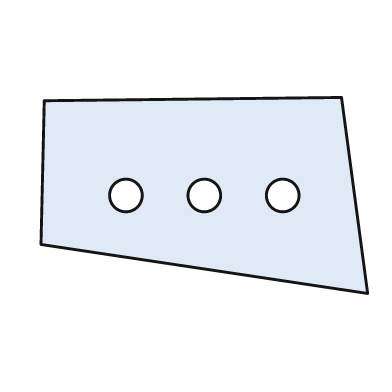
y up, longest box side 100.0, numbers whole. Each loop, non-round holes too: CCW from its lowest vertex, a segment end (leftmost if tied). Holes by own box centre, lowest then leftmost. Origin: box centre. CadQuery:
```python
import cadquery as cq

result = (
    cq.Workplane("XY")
    .moveTo(50.0, -30.0)
    .lineTo(42.0, 30.0)
    .lineTo(-49.0, 29.0)
    .lineTo(-50.0, -15.0)
    .close()
    .moveTo(-24.0, 0.0)
    .circle(5.0)
    .moveTo(0.0, 0.0)
    .circle(5.0)
    .moveTo(24.0, 0.0)
    .circle(5.0)
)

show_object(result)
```